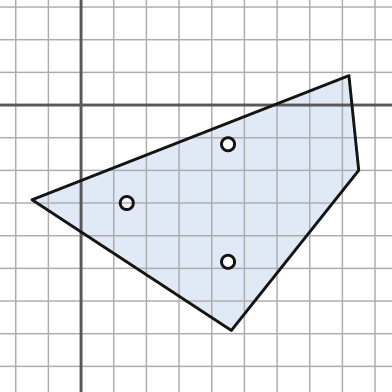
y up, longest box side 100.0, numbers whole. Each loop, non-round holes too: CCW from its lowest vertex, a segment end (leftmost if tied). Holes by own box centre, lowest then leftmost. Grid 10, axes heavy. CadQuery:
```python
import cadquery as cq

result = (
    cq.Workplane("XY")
    .moveTo(46.0, -69.0)
    .lineTo(85.0, -20.0)
    .lineTo(82.0, 9.0)
    .lineTo(-15.0, -29.0)
    .close()
    .moveTo(45.0, -48.0)
    .circle(2.0)
    .moveTo(14.0, -30.0)
    .circle(2.0)
    .moveTo(45.0, -12.0)
    .circle(2.0)
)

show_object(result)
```